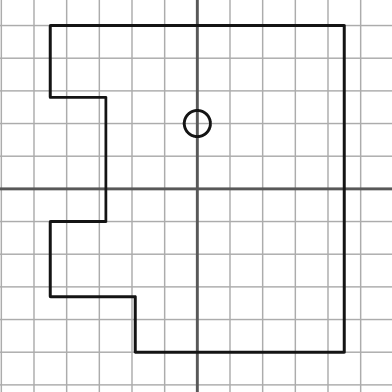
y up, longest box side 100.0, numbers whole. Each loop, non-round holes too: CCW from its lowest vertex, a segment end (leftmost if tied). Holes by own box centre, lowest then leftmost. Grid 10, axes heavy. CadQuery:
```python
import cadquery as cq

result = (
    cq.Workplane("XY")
    .moveTo(-19.0, -50.0)
    .lineTo(45.0, -50.0)
    .lineTo(45.0, 50.0)
    .lineTo(-45.0, 50.0)
    .lineTo(-45.0, 28.0)
    .lineTo(-28.0, 28.0)
    .lineTo(-28.0, -10.0)
    .lineTo(-45.0, -10.0)
    .lineTo(-45.0, -33.0)
    .lineTo(-19.0, -33.0)
    .close()
    .moveTo(0.0, 20.0)
    .circle(4.0)
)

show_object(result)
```